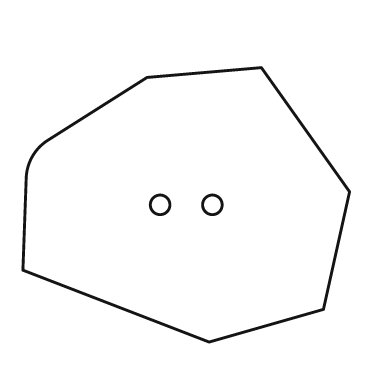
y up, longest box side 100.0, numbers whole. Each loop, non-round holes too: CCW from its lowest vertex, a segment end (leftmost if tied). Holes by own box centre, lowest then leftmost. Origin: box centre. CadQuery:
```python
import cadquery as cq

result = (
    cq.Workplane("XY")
    .moveTo(7.0, -42.0)
    .lineTo(42.0, -32.0)
    .lineTo(50.0, 4.0)
    .lineTo(23.0, 42.0)
    .lineTo(-12.0, 39.0)
    .lineTo(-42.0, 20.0)
    .threePointArc((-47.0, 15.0), (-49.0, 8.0))
    .lineTo(-50.0, -20.0)
    .close()
    .moveTo(-8.0, 0.0)
    .circle(3.0)
    .moveTo(8.0, 0.0)
    .circle(3.0)
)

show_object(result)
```